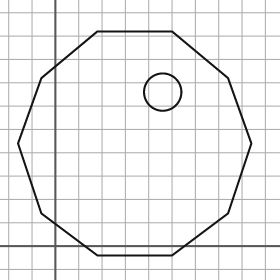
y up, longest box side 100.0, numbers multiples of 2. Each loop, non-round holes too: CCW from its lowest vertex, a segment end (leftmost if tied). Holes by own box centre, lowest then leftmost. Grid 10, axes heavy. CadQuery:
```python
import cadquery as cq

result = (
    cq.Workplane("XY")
    .moveTo(18.0, -4.0)
    .lineTo(50.0, -4.0)
    .lineTo(74.0, 14.0)
    .lineTo(84.0, 44.0)
    .lineTo(74.0, 72.0)
    .lineTo(50.0, 92.0)
    .lineTo(18.0, 92.0)
    .lineTo(-6.0, 72.0)
    .lineTo(-16.0, 44.0)
    .lineTo(-6.0, 14.0)
    .close()
    .moveTo(46.0, 66.0)
    .circle(8.0)
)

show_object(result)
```